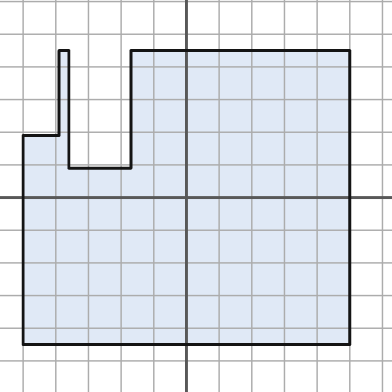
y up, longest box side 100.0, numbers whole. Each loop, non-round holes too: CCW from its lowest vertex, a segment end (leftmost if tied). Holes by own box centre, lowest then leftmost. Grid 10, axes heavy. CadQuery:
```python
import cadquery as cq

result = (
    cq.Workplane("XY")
    .moveTo(-50.0, -45.0)
    .lineTo(50.0, -45.0)
    .lineTo(50.0, 45.0)
    .lineTo(-17.0, 45.0)
    .lineTo(-17.0, 9.0)
    .lineTo(-36.0, 9.0)
    .lineTo(-36.0, 45.0)
    .lineTo(-39.0, 45.0)
    .lineTo(-39.0, 19.0)
    .lineTo(-50.0, 19.0)
    .close()
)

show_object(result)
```